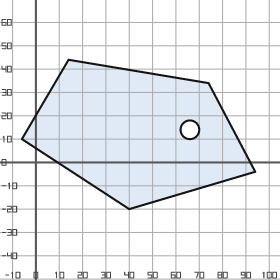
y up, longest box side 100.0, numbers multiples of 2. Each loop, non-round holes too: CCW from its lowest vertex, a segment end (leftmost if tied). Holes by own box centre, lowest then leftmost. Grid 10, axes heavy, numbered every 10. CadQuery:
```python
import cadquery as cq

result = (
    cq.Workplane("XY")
    .moveTo(40.0, -20.0)
    .lineTo(94.0, -4.0)
    .lineTo(74.0, 34.0)
    .lineTo(14.0, 44.0)
    .lineTo(-6.0, 10.0)
    .close()
    .moveTo(66.0, 14.0)
    .circle(4.0)
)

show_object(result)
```